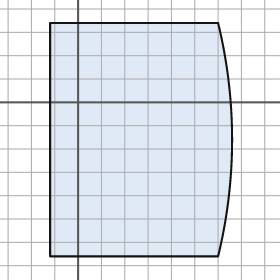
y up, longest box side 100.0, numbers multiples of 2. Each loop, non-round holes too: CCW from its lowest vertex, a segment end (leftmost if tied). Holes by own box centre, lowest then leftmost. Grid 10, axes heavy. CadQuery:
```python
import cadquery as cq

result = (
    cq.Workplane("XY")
    .moveTo(-12.0, -66.0)
    .lineTo(60.0, -66.0)
    .threePointArc((66.0, -16.0), (60.0, 34.0))
    .lineTo(-12.0, 34.0)
    .close()
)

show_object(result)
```